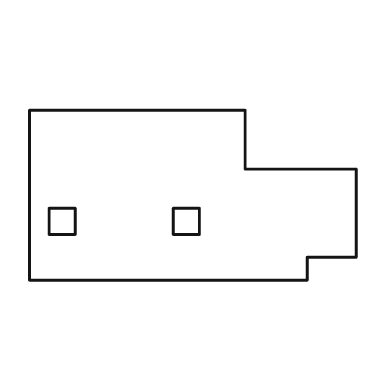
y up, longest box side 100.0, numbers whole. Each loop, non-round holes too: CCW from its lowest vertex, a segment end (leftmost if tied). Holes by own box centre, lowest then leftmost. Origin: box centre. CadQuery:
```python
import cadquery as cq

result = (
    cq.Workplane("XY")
    .moveTo(-50.0, -26.0)
    .lineTo(35.0, -26.0)
    .lineTo(35.0, -19.0)
    .lineTo(50.0, -19.0)
    .lineTo(50.0, 8.0)
    .lineTo(16.0, 8.0)
    .lineTo(16.0, 26.0)
    .lineTo(-50.0, 26.0)
    .close()
    .moveTo(-44.0, -12.0)
    .lineTo(-36.0, -12.0)
    .lineTo(-36.0, -4.0)
    .lineTo(-44.0, -4.0)
    .close()
    .moveTo(-6.0, -12.0)
    .lineTo(2.0, -12.0)
    .lineTo(2.0, -4.0)
    .lineTo(-6.0, -4.0)
    .close()
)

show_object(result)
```